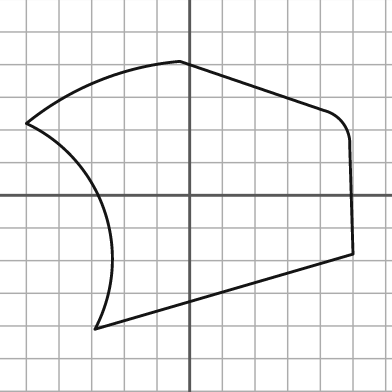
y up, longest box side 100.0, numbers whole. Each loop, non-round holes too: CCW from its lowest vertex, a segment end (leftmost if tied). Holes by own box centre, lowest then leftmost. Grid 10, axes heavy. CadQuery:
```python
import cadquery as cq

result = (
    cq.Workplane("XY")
    .moveTo(-29.0, -41.0)
    .lineTo(50.0, -18.0)
    .lineTo(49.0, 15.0)
    .threePointArc((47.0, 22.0), (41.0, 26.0))
    .lineTo(-3.0, 41.0)
    .threePointArc((-28.0, 35.0), (-50.0, 22.0))
    .threePointArc((-26.0, -5.0), (-29.0, -41.0))
    .close()
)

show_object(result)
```